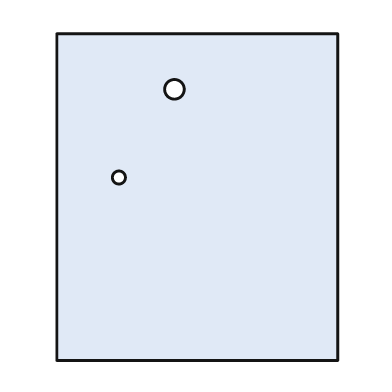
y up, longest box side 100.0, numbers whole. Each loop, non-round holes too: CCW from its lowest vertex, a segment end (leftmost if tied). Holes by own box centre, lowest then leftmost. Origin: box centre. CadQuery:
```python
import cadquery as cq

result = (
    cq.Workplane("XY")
    .moveTo(-43.0, -50.0)
    .lineTo(43.0, -50.0)
    .lineTo(43.0, 50.0)
    .lineTo(-43.0, 50.0)
    .close()
    .moveTo(-24.0, 6.0)
    .circle(2.0)
    .moveTo(-7.0, 33.0)
    .circle(3.0)
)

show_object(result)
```